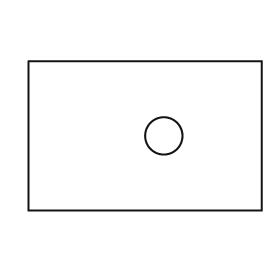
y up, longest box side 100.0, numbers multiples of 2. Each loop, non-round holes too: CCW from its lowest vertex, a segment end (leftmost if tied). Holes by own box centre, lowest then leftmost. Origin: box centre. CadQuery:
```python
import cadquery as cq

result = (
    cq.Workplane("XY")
    .moveTo(-50.0, -32.0)
    .lineTo(50.0, -32.0)
    .lineTo(50.0, 32.0)
    .lineTo(-50.0, 32.0)
    .close()
    .moveTo(8.0, 0.0)
    .circle(8.0)
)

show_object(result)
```